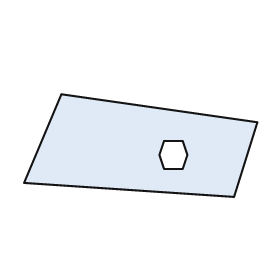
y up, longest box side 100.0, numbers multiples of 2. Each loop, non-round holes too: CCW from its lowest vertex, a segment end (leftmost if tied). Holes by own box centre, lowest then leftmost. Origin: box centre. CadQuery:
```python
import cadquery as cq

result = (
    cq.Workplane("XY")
    .moveTo(40.0, -22.0)
    .lineTo(50.0, 10.0)
    .lineTo(-34.0, 22.0)
    .lineTo(-50.0, -16.0)
    .close()
    .moveTo(10.0, -10.0)
    .lineTo(18.0, -10.0)
    .lineTo(20.0, -4.0)
    .lineTo(18.0, 2.0)
    .lineTo(10.0, 2.0)
    .lineTo(8.0, -4.0)
    .close()
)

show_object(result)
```